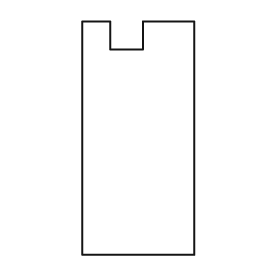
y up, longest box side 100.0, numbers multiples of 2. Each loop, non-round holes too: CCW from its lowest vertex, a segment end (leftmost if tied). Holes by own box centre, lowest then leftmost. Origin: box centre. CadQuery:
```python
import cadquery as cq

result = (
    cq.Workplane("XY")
    .moveTo(-24.0, -50.0)
    .lineTo(24.0, -50.0)
    .lineTo(24.0, 50.0)
    .lineTo(2.0, 50.0)
    .lineTo(2.0, 38.0)
    .lineTo(-12.0, 38.0)
    .lineTo(-12.0, 50.0)
    .lineTo(-24.0, 50.0)
    .close()
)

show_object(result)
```